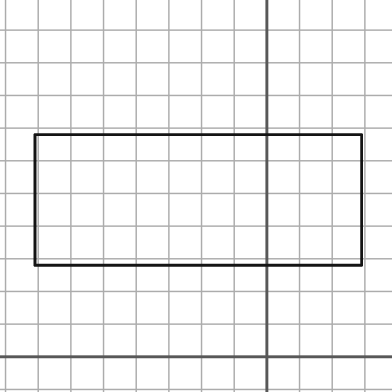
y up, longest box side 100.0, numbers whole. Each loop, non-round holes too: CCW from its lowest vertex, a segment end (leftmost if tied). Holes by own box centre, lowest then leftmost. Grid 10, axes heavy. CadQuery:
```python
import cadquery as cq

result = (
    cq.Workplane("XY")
    .moveTo(-71.0, 28.0)
    .lineTo(29.0, 28.0)
    .lineTo(29.0, 68.0)
    .lineTo(-71.0, 68.0)
    .close()
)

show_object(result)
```